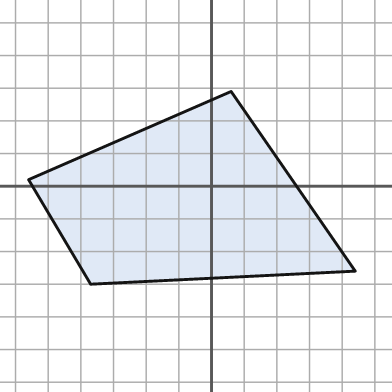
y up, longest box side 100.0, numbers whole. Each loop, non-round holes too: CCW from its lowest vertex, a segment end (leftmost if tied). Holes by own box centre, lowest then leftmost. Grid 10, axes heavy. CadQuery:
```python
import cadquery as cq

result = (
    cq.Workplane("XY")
    .moveTo(-37.0, -30.0)
    .lineTo(44.0, -26.0)
    .lineTo(6.0, 29.0)
    .lineTo(-56.0, 2.0)
    .close()
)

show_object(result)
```